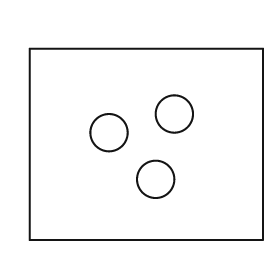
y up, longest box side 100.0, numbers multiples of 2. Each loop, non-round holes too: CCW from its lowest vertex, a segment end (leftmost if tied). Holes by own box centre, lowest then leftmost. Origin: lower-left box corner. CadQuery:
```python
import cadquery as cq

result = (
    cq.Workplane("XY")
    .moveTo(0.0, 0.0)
    .lineTo(100.0, 0.0)
    .lineTo(100.0, 82.0)
    .lineTo(0.0, 82.0)
    .close()
    .moveTo(54.0, 26.0)
    .circle(8.0)
    .moveTo(34.0, 46.0)
    .circle(8.0)
    .moveTo(62.0, 54.0)
    .circle(8.0)
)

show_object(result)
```